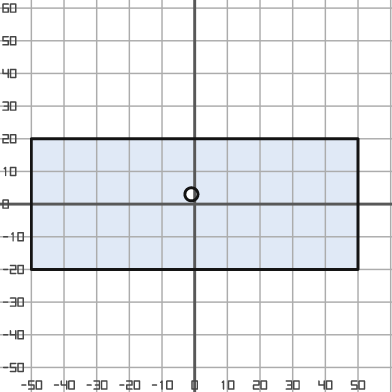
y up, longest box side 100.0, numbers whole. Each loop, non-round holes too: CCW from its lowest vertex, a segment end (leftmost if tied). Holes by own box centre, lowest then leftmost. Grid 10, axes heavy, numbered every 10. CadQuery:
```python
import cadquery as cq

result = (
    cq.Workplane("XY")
    .moveTo(-50.0, -20.0)
    .lineTo(50.0, -20.0)
    .lineTo(50.0, 20.0)
    .lineTo(-50.0, 20.0)
    .close()
    .moveTo(-1.0, 3.0)
    .circle(2.0)
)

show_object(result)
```